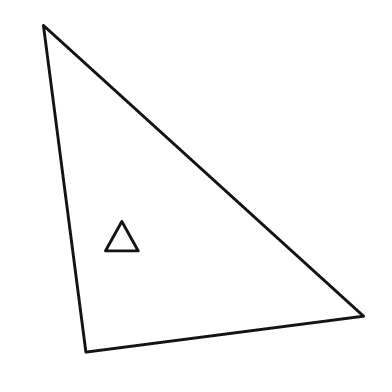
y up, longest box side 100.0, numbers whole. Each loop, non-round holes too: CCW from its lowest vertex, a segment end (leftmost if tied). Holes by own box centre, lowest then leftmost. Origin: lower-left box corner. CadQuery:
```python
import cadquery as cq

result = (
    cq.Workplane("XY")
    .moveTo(13.0, 0.0)
    .lineTo(98.0, 11.0)
    .lineTo(0.0, 100.0)
    .close()
    .moveTo(19.0, 31.0)
    .lineTo(29.0, 31.0)
    .lineTo(24.0, 40.0)
    .close()
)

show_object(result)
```